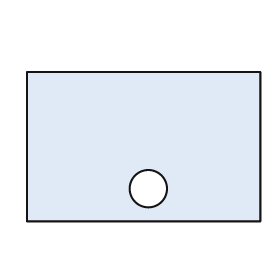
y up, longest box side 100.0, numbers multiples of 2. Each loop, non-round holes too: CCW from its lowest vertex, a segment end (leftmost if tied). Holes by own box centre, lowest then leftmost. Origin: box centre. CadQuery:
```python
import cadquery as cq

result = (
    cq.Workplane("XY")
    .moveTo(-50.0, -32.0)
    .lineTo(50.0, -32.0)
    .lineTo(50.0, 32.0)
    .lineTo(-50.0, 32.0)
    .close()
    .moveTo(2.0, -18.0)
    .circle(8.0)
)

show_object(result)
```